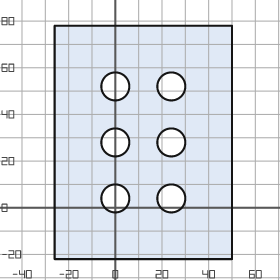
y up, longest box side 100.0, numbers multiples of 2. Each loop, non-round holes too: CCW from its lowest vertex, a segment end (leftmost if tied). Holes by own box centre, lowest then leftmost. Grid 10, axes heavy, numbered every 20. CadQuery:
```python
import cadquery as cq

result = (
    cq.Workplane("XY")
    .moveTo(-26.0, -22.0)
    .lineTo(50.0, -22.0)
    .lineTo(50.0, 78.0)
    .lineTo(-26.0, 78.0)
    .close()
    .moveTo(0.0, 4.0)
    .circle(6.0)
    .moveTo(24.0, 4.0)
    .circle(6.0)
    .moveTo(0.0, 28.0)
    .circle(6.0)
    .moveTo(24.0, 28.0)
    .circle(6.0)
    .moveTo(0.0, 52.0)
    .circle(6.0)
    .moveTo(24.0, 52.0)
    .circle(6.0)
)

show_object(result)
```